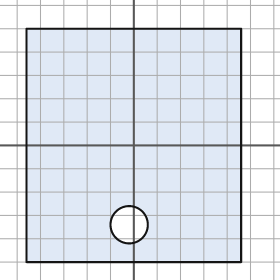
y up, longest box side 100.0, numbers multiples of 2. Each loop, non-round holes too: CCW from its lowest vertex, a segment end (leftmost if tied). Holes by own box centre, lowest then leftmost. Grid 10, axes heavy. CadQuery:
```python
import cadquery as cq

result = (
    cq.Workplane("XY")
    .moveTo(-46.0, -50.0)
    .lineTo(46.0, -50.0)
    .lineTo(46.0, 50.0)
    .lineTo(-46.0, 50.0)
    .close()
    .moveTo(-2.0, -34.0)
    .circle(8.0)
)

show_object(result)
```